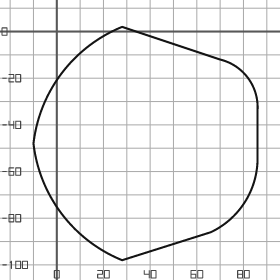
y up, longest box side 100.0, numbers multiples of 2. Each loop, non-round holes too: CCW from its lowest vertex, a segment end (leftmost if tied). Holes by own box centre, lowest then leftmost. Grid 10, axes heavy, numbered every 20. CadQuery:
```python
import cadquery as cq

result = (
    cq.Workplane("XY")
    .moveTo(28.0, -98.0)
    .lineTo(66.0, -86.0)
    .threePointArc((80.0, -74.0), (86.0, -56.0))
    .lineTo(86.0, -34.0)
    .threePointArc((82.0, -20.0), (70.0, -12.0))
    .lineTo(28.0, 2.0)
    .threePointArc((2.0, -18.0), (-10.0, -48.0))
    .threePointArc((2.0, -78.0), (28.0, -98.0))
    .close()
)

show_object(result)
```